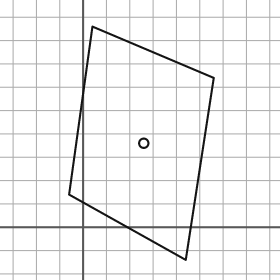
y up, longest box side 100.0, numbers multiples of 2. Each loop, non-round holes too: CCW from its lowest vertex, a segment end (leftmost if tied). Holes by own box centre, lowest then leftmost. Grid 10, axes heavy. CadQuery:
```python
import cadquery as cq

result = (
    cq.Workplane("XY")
    .moveTo(44.0, -14.0)
    .lineTo(56.0, 64.0)
    .lineTo(4.0, 86.0)
    .lineTo(-6.0, 14.0)
    .close()
    .moveTo(26.0, 36.0)
    .circle(2.0)
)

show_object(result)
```